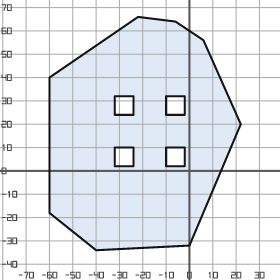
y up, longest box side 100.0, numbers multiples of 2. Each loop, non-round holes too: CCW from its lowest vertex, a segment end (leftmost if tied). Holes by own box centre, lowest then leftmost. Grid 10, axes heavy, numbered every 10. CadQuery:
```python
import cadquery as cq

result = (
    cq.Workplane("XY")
    .moveTo(-40.0, -34.0)
    .lineTo(0.0, -32.0)
    .lineTo(22.0, 20.0)
    .lineTo(6.0, 56.0)
    .lineTo(-6.0, 64.0)
    .lineTo(-22.0, 66.0)
    .lineTo(-60.0, 40.0)
    .lineTo(-60.0, -18.0)
    .close()
    .moveTo(-32.0, 2.0)
    .lineTo(-24.0, 2.0)
    .lineTo(-24.0, 10.0)
    .lineTo(-32.0, 10.0)
    .close()
    .moveTo(-10.0, 2.0)
    .lineTo(-2.0, 2.0)
    .lineTo(-2.0, 10.0)
    .lineTo(-10.0, 10.0)
    .close()
    .moveTo(-32.0, 24.0)
    .lineTo(-24.0, 24.0)
    .lineTo(-24.0, 32.0)
    .lineTo(-32.0, 32.0)
    .close()
    .moveTo(-10.0, 24.0)
    .lineTo(-2.0, 24.0)
    .lineTo(-2.0, 32.0)
    .lineTo(-10.0, 32.0)
    .close()
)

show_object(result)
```